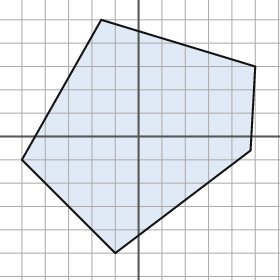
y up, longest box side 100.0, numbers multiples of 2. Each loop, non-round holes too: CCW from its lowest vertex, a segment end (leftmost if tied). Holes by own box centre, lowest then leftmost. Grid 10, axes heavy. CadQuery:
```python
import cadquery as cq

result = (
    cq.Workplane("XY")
    .moveTo(-10.0, -50.0)
    .lineTo(48.0, -6.0)
    .lineTo(50.0, 30.0)
    .lineTo(-16.0, 50.0)
    .lineTo(-50.0, -10.0)
    .close()
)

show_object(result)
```